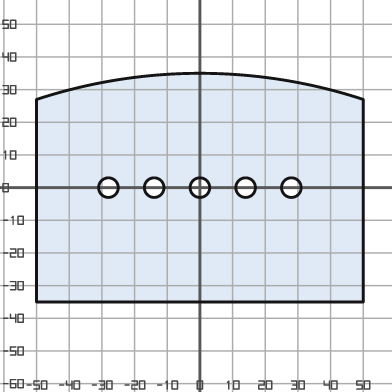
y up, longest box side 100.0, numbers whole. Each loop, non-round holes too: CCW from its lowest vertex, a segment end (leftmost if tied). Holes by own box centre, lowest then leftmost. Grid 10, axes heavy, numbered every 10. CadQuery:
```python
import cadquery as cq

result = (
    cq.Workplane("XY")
    .moveTo(-50.0, -35.0)
    .lineTo(50.0, -35.0)
    .lineTo(50.0, 27.0)
    .threePointArc((0.0, 35.0), (-50.0, 27.0))
    .close()
    .moveTo(-28.0, 0.0)
    .circle(3.0)
    .moveTo(-14.0, 0.0)
    .circle(3.0)
    .moveTo(0.0, 0.0)
    .circle(3.0)
    .moveTo(14.0, 0.0)
    .circle(3.0)
    .moveTo(28.0, 0.0)
    .circle(3.0)
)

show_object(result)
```